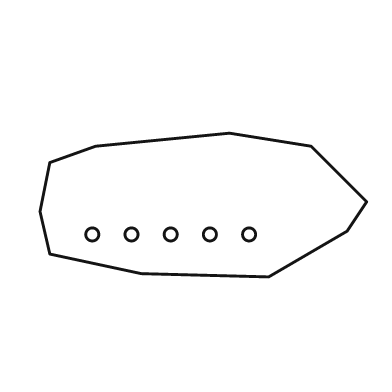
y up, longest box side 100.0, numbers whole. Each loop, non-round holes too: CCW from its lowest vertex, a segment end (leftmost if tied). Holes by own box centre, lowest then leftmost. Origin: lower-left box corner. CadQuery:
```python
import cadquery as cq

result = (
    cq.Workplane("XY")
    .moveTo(70.0, 0.0)
    .lineTo(94.0, 14.0)
    .lineTo(100.0, 23.0)
    .lineTo(83.0, 40.0)
    .lineTo(58.0, 44.0)
    .lineTo(17.0, 40.0)
    .lineTo(3.0, 35.0)
    .lineTo(0.0, 20.0)
    .lineTo(3.0, 7.0)
    .lineTo(31.0, 1.0)
    .close()
    .moveTo(16.0, 13.0)
    .circle(2.0)
    .moveTo(28.0, 13.0)
    .circle(2.0)
    .moveTo(40.0, 13.0)
    .circle(2.0)
    .moveTo(52.0, 13.0)
    .circle(2.0)
    .moveTo(64.0, 13.0)
    .circle(2.0)
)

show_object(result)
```